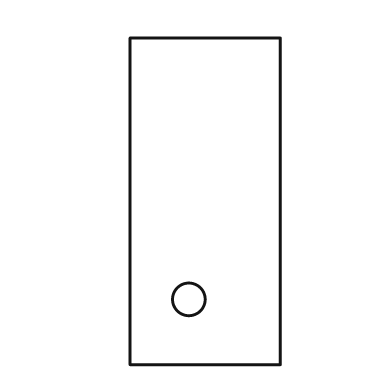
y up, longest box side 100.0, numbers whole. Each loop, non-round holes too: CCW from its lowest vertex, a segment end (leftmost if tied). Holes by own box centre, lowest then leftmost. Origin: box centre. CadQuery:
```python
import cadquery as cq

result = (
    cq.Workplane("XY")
    .moveTo(-23.0, -50.0)
    .lineTo(23.0, -50.0)
    .lineTo(23.0, 50.0)
    .lineTo(-23.0, 50.0)
    .close()
    .moveTo(-5.0, -30.0)
    .circle(5.0)
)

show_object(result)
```